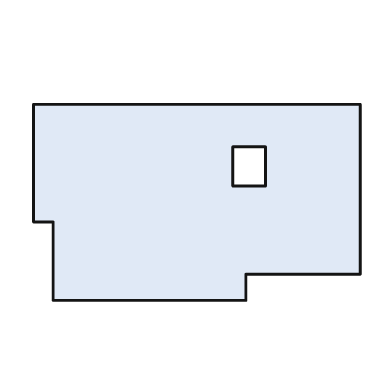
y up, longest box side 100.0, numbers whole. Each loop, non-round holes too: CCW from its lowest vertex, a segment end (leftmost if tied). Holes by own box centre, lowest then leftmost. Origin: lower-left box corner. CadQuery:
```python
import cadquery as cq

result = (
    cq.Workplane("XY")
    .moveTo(6.0, 0.0)
    .lineTo(65.0, 0.0)
    .lineTo(65.0, 8.0)
    .lineTo(100.0, 8.0)
    .lineTo(100.0, 60.0)
    .lineTo(0.0, 60.0)
    .lineTo(0.0, 24.0)
    .lineTo(6.0, 24.0)
    .close()
    .moveTo(61.0, 35.0)
    .lineTo(71.0, 35.0)
    .lineTo(71.0, 47.0)
    .lineTo(61.0, 47.0)
    .close()
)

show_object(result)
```